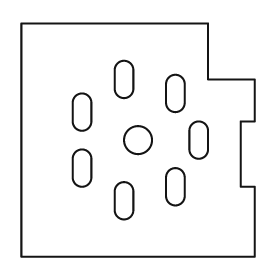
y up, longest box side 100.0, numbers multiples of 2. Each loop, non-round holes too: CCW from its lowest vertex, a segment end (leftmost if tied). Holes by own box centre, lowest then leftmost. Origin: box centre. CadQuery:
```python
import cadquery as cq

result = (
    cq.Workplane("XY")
    .moveTo(-50.0, -50.0)
    .lineTo(50.0, -50.0)
    .lineTo(50.0, -20.0)
    .lineTo(44.0, -20.0)
    .lineTo(44.0, 8.0)
    .lineTo(50.0, 8.0)
    .lineTo(50.0, 26.0)
    .lineTo(30.0, 26.0)
    .lineTo(30.0, 50.0)
    .lineTo(-50.0, 50.0)
    .close()
    .moveTo(-10.0, -30.0)
    .threePointArc((-6.0, -34.0), (-2.0, -30.0))
    .lineTo(-2.0, -22.0)
    .threePointArc((-6.0, -18.0), (-10.0, -22.0))
    .close()
    .moveTo(12.0, -24.0)
    .threePointArc((16.0, -28.0), (20.0, -24.0))
    .lineTo(20.0, -16.0)
    .threePointArc((16.0, -12.0), (12.0, -16.0))
    .close()
    .moveTo(-28.0, -16.0)
    .threePointArc((-24.0, -20.0), (-20.0, -16.0))
    .lineTo(-20.0, -8.0)
    .threePointArc((-24.0, -4.0), (-28.0, -8.0))
    .close()
    .moveTo(0.0, 0.0)
    .circle(6.0)
    .moveTo(22.0, -4.0)
    .threePointArc((26.0, -8.0), (30.0, -4.0))
    .lineTo(30.0, 4.0)
    .threePointArc((26.0, 8.0), (22.0, 4.0))
    .close()
    .moveTo(-28.0, 8.0)
    .threePointArc((-24.0, 4.0), (-20.0, 8.0))
    .lineTo(-20.0, 16.0)
    .threePointArc((-24.0, 20.0), (-28.0, 16.0))
    .close()
    .moveTo(12.0, 16.0)
    .threePointArc((16.0, 12.0), (20.0, 16.0))
    .lineTo(20.0, 24.0)
    .threePointArc((16.0, 28.0), (12.0, 24.0))
    .close()
    .moveTo(-10.0, 22.0)
    .threePointArc((-6.0, 18.0), (-2.0, 22.0))
    .lineTo(-2.0, 30.0)
    .threePointArc((-6.0, 34.0), (-10.0, 30.0))
    .close()
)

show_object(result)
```